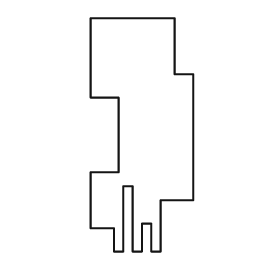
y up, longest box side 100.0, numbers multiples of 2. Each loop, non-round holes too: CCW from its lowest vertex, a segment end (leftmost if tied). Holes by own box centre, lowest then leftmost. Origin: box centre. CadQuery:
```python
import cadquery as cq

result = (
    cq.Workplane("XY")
    .moveTo(-12.0, -50.0)
    .lineTo(-8.0, -50.0)
    .lineTo(-8.0, -22.0)
    .lineTo(-4.0, -22.0)
    .lineTo(-4.0, -50.0)
    .lineTo(0.0, -50.0)
    .lineTo(0.0, -38.0)
    .lineTo(4.0, -38.0)
    .lineTo(4.0, -50.0)
    .lineTo(8.0, -50.0)
    .lineTo(8.0, -28.0)
    .lineTo(22.0, -28.0)
    .lineTo(22.0, 26.0)
    .lineTo(14.0, 26.0)
    .lineTo(14.0, 50.0)
    .lineTo(-22.0, 50.0)
    .lineTo(-22.0, 16.0)
    .lineTo(-10.0, 16.0)
    .lineTo(-10.0, -16.0)
    .lineTo(-22.0, -16.0)
    .lineTo(-22.0, -40.0)
    .lineTo(-12.0, -40.0)
    .close()
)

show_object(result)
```